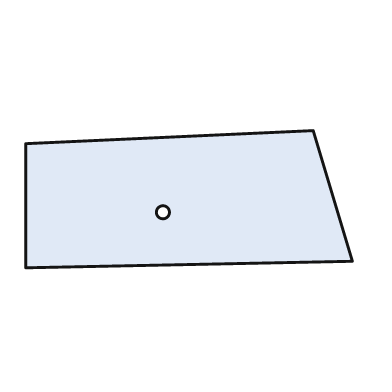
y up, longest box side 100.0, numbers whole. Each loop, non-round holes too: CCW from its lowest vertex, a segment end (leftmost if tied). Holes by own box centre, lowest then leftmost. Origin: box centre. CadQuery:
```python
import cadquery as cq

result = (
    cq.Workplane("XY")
    .moveTo(-50.0, -21.0)
    .lineTo(50.0, -19.0)
    .lineTo(38.0, 21.0)
    .lineTo(-50.0, 17.0)
    .close()
    .moveTo(-8.0, -4.0)
    .circle(2.0)
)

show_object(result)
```